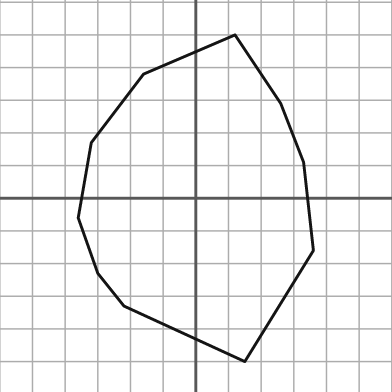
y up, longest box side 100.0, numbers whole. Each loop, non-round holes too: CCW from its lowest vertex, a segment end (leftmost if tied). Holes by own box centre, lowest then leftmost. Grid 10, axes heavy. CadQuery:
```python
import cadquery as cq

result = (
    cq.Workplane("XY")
    .moveTo(15.0, -50.0)
    .lineTo(36.0, -16.0)
    .lineTo(33.0, 11.0)
    .lineTo(26.0, 29.0)
    .lineTo(12.0, 50.0)
    .lineTo(-16.0, 38.0)
    .lineTo(-32.0, 17.0)
    .lineTo(-36.0, -6.0)
    .lineTo(-30.0, -23.0)
    .lineTo(-22.0, -33.0)
    .close()
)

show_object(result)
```